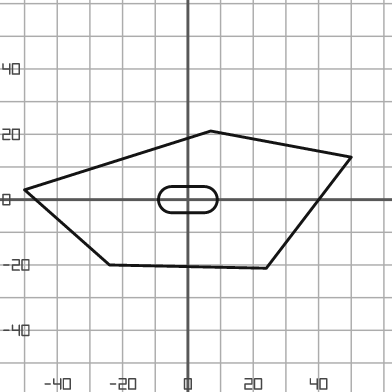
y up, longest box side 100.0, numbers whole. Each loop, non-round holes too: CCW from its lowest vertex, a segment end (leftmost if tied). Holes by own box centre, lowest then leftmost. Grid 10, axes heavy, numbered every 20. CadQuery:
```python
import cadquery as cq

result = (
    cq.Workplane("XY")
    .moveTo(24.0, -21.0)
    .lineTo(50.0, 13.0)
    .lineTo(7.0, 21.0)
    .lineTo(-50.0, 3.0)
    .lineTo(-24.0, -20.0)
    .close()
    .moveTo(-5.0, -4.0)
    .lineTo(5.0, -4.0)
    .threePointArc((9.0, 0.0), (5.0, 4.0))
    .lineTo(-5.0, 4.0)
    .threePointArc((-9.0, 0.0), (-5.0, -4.0))
    .close()
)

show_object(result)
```